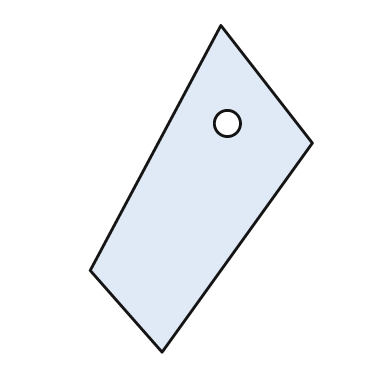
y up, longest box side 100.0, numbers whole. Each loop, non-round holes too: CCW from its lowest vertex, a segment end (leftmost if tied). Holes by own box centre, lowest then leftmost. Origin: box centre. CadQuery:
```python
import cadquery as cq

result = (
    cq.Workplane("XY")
    .moveTo(-12.0, -50.0)
    .lineTo(34.0, 14.0)
    .lineTo(6.0, 50.0)
    .lineTo(-34.0, -25.0)
    .close()
    .moveTo(8.0, 20.0)
    .circle(4.0)
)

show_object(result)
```